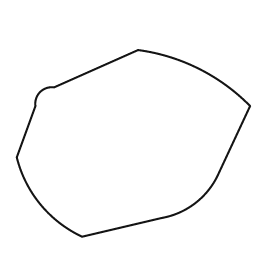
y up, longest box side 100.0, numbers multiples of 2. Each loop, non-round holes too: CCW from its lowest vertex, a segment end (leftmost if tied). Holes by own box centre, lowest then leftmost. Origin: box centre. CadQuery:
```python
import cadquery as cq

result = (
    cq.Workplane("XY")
    .moveTo(-22.0, -40.0)
    .lineTo(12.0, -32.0)
    .threePointArc((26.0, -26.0), (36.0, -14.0))
    .lineTo(50.0, 16.0)
    .threePointArc((28.0, 32.0), (2.0, 40.0))
    .lineTo(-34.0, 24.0)
    .threePointArc((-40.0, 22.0), (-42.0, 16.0))
    .lineTo(-50.0, -6.0)
    .threePointArc((-40.0, -26.0), (-22.0, -40.0))
    .close()
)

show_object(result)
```